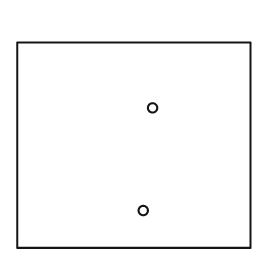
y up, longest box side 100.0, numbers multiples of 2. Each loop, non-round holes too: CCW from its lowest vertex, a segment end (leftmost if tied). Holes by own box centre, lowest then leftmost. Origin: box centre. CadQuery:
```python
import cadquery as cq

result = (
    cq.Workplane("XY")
    .moveTo(-50.0, -44.0)
    .lineTo(50.0, -44.0)
    .lineTo(50.0, 44.0)
    .lineTo(-50.0, 44.0)
    .close()
    .moveTo(4.0, -28.0)
    .circle(2.0)
    .moveTo(8.0, 16.0)
    .circle(2.0)
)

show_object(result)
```